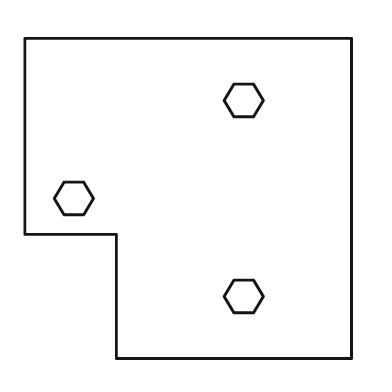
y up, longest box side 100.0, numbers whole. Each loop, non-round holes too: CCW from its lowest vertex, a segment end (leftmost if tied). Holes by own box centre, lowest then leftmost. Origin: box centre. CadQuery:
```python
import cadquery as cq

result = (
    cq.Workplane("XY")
    .moveTo(-22.0, -49.0)
    .lineTo(50.0, -49.0)
    .lineTo(50.0, 49.0)
    .lineTo(-50.0, 49.0)
    .lineTo(-50.0, -11.0)
    .lineTo(-22.0, -11.0)
    .close()
    .moveTo(14.0, -35.0)
    .lineTo(20.0, -35.0)
    .lineTo(23.0, -30.0)
    .lineTo(20.0, -25.0)
    .lineTo(14.0, -25.0)
    .lineTo(11.0, -30.0)
    .close()
    .moveTo(-38.0, -5.0)
    .lineTo(-32.0, -5.0)
    .lineTo(-29.0, 0.0)
    .lineTo(-32.0, 5.0)
    .lineTo(-38.0, 5.0)
    .lineTo(-41.0, 0.0)
    .close()
    .moveTo(14.0, 25.0)
    .lineTo(20.0, 25.0)
    .lineTo(23.0, 30.0)
    .lineTo(20.0, 35.0)
    .lineTo(14.0, 35.0)
    .lineTo(11.0, 30.0)
    .close()
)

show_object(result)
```